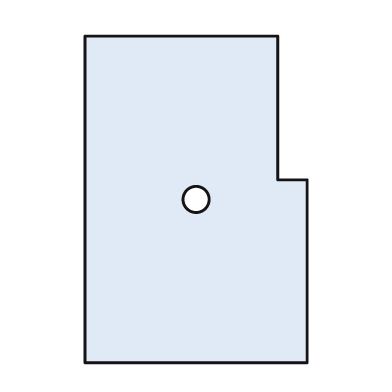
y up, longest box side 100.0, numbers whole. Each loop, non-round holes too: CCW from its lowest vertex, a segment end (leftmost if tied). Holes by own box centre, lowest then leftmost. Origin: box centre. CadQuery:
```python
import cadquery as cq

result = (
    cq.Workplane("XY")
    .moveTo(-34.0, -50.0)
    .lineTo(34.0, -50.0)
    .lineTo(34.0, 6.0)
    .lineTo(25.0, 6.0)
    .lineTo(25.0, 50.0)
    .lineTo(-34.0, 50.0)
    .close()
    .moveTo(0.0, 0.0)
    .circle(4.0)
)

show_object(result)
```